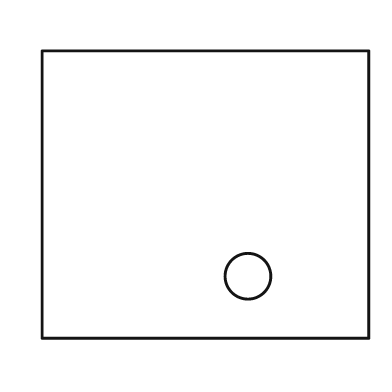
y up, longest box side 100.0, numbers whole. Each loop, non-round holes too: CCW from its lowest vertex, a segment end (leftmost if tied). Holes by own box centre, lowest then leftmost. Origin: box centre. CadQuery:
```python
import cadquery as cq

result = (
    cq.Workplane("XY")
    .moveTo(-50.0, -44.0)
    .lineTo(50.0, -44.0)
    .lineTo(50.0, 44.0)
    .lineTo(-50.0, 44.0)
    .close()
    .moveTo(13.0, -25.0)
    .circle(7.0)
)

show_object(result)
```